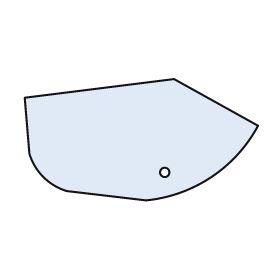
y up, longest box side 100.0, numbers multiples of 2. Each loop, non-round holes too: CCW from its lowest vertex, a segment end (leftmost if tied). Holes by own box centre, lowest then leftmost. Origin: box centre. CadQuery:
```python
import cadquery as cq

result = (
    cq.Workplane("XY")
    .moveTo(2.0, -26.0)
    .threePointArc((30.0, -16.0), (50.0, 6.0))
    .lineTo(14.0, 26.0)
    .lineTo(-50.0, 18.0)
    .lineTo(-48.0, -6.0)
    .threePointArc((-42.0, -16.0), (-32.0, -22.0))
    .close()
    .moveTo(10.0, -14.0)
    .circle(2.0)
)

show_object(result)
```